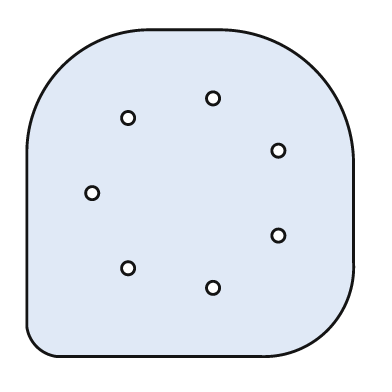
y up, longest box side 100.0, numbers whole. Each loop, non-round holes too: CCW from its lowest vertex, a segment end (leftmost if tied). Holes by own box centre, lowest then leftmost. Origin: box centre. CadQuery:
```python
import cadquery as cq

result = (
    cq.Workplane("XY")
    .moveTo(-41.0, -50.0)
    .lineTo(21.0, -50.0)
    .threePointArc((42.0, -42.0), (50.0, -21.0))
    .lineTo(50.0, 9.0)
    .threePointArc((38.0, 38.0), (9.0, 50.0))
    .lineTo(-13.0, 50.0)
    .threePointArc((-39.0, 39.0), (-50.0, 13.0))
    .lineTo(-50.0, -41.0)
    .threePointArc((-47.0, -47.0), (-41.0, -50.0))
    .close()
    .moveTo(7.0, -29.0)
    .circle(2.0)
    .moveTo(-19.0, -23.0)
    .circle(2.0)
    .moveTo(27.0, -13.0)
    .circle(2.0)
    .moveTo(-30.0, 0.0)
    .circle(2.0)
    .moveTo(27.0, 13.0)
    .circle(2.0)
    .moveTo(-19.0, 23.0)
    .circle(2.0)
    .moveTo(7.0, 29.0)
    .circle(2.0)
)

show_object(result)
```